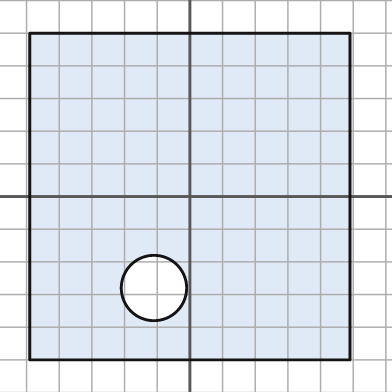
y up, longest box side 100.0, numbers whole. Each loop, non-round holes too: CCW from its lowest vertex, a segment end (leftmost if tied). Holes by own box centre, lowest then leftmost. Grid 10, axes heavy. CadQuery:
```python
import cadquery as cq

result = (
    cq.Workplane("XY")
    .moveTo(-49.0, -50.0)
    .lineTo(49.0, -50.0)
    .lineTo(49.0, 50.0)
    .lineTo(-49.0, 50.0)
    .close()
    .moveTo(-11.0, -28.0)
    .circle(10.0)
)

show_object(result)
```